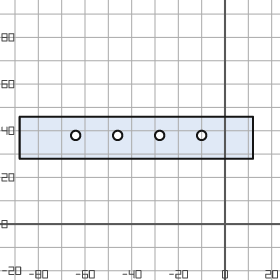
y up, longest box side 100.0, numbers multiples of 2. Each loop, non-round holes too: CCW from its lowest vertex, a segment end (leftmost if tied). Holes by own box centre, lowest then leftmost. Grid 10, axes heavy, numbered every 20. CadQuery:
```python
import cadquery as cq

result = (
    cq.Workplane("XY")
    .moveTo(-88.0, 28.0)
    .lineTo(12.0, 28.0)
    .lineTo(12.0, 46.0)
    .lineTo(-88.0, 46.0)
    .close()
    .moveTo(-64.0, 38.0)
    .circle(2.0)
    .moveTo(-46.0, 38.0)
    .circle(2.0)
    .moveTo(-28.0, 38.0)
    .circle(2.0)
    .moveTo(-10.0, 38.0)
    .circle(2.0)
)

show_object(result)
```